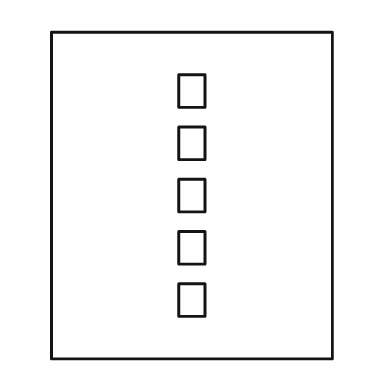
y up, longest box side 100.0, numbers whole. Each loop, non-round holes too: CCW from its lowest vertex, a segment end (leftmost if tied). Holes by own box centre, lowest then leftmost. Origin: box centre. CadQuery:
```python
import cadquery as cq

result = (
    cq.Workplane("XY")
    .moveTo(-43.0, -50.0)
    .lineTo(43.0, -50.0)
    .lineTo(43.0, 50.0)
    .lineTo(-43.0, 50.0)
    .close()
    .moveTo(-4.0, -37.0)
    .lineTo(4.0, -37.0)
    .lineTo(4.0, -27.0)
    .lineTo(-4.0, -27.0)
    .close()
    .moveTo(-4.0, -21.0)
    .lineTo(4.0, -21.0)
    .lineTo(4.0, -11.0)
    .lineTo(-4.0, -11.0)
    .close()
    .moveTo(-4.0, -5.0)
    .lineTo(4.0, -5.0)
    .lineTo(4.0, 5.0)
    .lineTo(-4.0, 5.0)
    .close()
    .moveTo(-4.0, 11.0)
    .lineTo(4.0, 11.0)
    .lineTo(4.0, 21.0)
    .lineTo(-4.0, 21.0)
    .close()
    .moveTo(-4.0, 27.0)
    .lineTo(4.0, 27.0)
    .lineTo(4.0, 37.0)
    .lineTo(-4.0, 37.0)
    .close()
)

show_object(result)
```